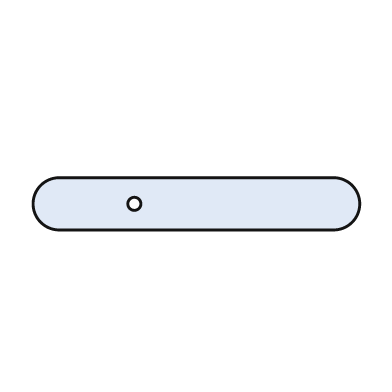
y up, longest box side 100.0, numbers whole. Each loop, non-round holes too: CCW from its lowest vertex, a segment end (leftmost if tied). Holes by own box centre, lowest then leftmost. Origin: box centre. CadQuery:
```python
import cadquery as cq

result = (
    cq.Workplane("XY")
    .moveTo(-42.0, -8.0)
    .lineTo(42.0, -8.0)
    .threePointArc((50.0, 0.0), (42.0, 8.0))
    .lineTo(-42.0, 8.0)
    .threePointArc((-50.0, 0.0), (-42.0, -8.0))
    .close()
    .moveTo(-19.0, 0.0)
    .circle(2.0)
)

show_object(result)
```